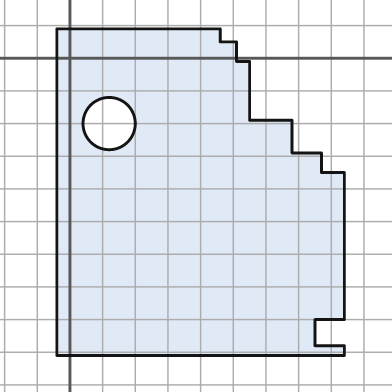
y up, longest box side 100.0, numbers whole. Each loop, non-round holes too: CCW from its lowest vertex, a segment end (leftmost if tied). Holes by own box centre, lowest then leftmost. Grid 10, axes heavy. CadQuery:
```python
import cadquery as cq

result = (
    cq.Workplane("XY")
    .moveTo(-4.0, -91.0)
    .lineTo(84.0, -91.0)
    .lineTo(84.0, -88.0)
    .lineTo(75.0, -88.0)
    .lineTo(75.0, -80.0)
    .lineTo(84.0, -80.0)
    .lineTo(84.0, -35.0)
    .lineTo(77.0, -35.0)
    .lineTo(77.0, -29.0)
    .lineTo(68.0, -29.0)
    .lineTo(68.0, -19.0)
    .lineTo(55.0, -19.0)
    .lineTo(55.0, -1.0)
    .lineTo(51.0, -1.0)
    .lineTo(51.0, 5.0)
    .lineTo(46.0, 5.0)
    .lineTo(46.0, 9.0)
    .lineTo(-4.0, 9.0)
    .close()
    .moveTo(12.0, -20.0)
    .circle(8.0)
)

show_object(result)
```